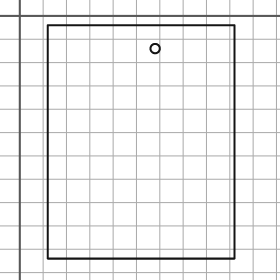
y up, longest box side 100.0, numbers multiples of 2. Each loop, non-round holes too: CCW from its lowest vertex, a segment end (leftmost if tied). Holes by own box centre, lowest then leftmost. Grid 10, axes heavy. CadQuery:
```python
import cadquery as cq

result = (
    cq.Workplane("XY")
    .moveTo(12.0, -104.0)
    .lineTo(92.0, -104.0)
    .lineTo(92.0, -4.0)
    .lineTo(12.0, -4.0)
    .close()
    .moveTo(58.0, -14.0)
    .circle(2.0)
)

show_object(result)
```